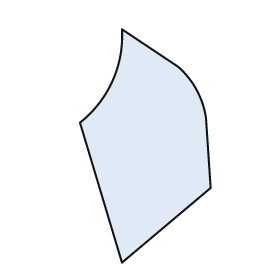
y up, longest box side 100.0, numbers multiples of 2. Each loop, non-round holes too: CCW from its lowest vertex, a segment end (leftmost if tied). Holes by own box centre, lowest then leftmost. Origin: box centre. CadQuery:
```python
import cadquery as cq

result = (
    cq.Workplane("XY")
    .moveTo(-10.0, -50.0)
    .lineTo(28.0, -18.0)
    .lineTo(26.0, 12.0)
    .threePointArc((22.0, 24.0), (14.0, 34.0))
    .lineTo(-10.0, 50.0)
    .threePointArc((-14.0, 28.0), (-28.0, 10.0))
    .close()
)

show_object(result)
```